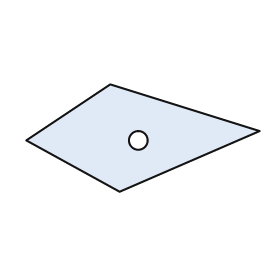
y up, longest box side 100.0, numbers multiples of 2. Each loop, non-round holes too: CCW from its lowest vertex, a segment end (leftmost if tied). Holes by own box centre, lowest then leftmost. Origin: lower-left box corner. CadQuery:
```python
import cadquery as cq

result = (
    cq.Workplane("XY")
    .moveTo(40.0, 0.0)
    .lineTo(100.0, 26.0)
    .lineTo(36.0, 46.0)
    .lineTo(0.0, 22.0)
    .close()
    .moveTo(48.0, 22.0)
    .circle(4.0)
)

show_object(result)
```